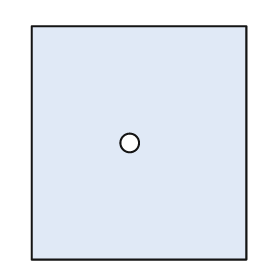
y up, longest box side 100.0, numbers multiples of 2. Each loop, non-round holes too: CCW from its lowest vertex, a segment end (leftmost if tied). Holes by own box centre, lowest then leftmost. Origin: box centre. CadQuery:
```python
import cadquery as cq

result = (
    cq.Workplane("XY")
    .moveTo(-46.0, -50.0)
    .lineTo(46.0, -50.0)
    .lineTo(46.0, 50.0)
    .lineTo(-46.0, 50.0)
    .close()
    .moveTo(-4.0, 0.0)
    .circle(4.0)
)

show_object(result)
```